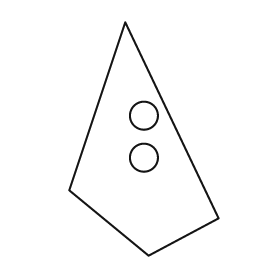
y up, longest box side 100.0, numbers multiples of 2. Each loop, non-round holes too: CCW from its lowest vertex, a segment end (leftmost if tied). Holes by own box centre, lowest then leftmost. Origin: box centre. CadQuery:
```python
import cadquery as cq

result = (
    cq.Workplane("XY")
    .moveTo(2.0, -50.0)
    .lineTo(32.0, -34.0)
    .lineTo(-8.0, 50.0)
    .lineTo(-32.0, -22.0)
    .close()
    .moveTo(0.0, -8.0)
    .circle(6.0)
    .moveTo(0.0, 10.0)
    .circle(6.0)
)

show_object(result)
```